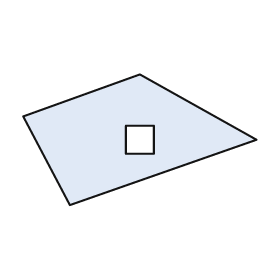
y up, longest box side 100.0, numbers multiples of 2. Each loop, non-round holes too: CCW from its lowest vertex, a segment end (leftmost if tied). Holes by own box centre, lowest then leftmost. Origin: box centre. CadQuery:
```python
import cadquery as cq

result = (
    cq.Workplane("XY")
    .moveTo(-30.0, -28.0)
    .lineTo(50.0, 0.0)
    .lineTo(0.0, 28.0)
    .lineTo(-50.0, 10.0)
    .close()
    .moveTo(-6.0, -6.0)
    .lineTo(6.0, -6.0)
    .lineTo(6.0, 6.0)
    .lineTo(-6.0, 6.0)
    .close()
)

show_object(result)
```